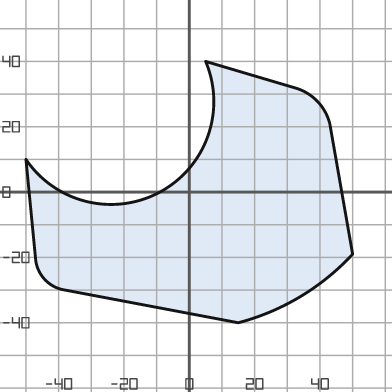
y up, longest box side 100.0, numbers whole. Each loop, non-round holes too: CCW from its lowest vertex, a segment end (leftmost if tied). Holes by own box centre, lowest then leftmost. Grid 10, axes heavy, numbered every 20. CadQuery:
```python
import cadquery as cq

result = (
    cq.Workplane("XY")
    .moveTo(15.0, -40.0)
    .threePointArc((34.0, -32.0), (50.0, -19.0))
    .lineTo(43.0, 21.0)
    .threePointArc((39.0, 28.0), (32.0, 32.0))
    .lineTo(5.0, 40.0)
    .threePointArc((-9.0, 0.0), (-50.0, 10.0))
    .lineTo(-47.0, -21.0)
    .threePointArc((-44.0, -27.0), (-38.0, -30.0))
    .close()
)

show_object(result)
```